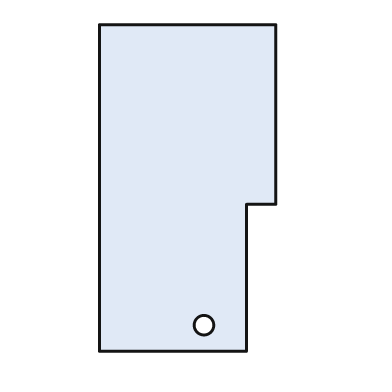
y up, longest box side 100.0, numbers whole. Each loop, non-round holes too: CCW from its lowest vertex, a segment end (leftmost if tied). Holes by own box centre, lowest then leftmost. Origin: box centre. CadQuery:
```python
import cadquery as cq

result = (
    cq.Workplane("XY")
    .moveTo(-27.0, -50.0)
    .lineTo(18.0, -50.0)
    .lineTo(18.0, -5.0)
    .lineTo(27.0, -5.0)
    .lineTo(27.0, 50.0)
    .lineTo(-27.0, 50.0)
    .close()
    .moveTo(5.0, -42.0)
    .circle(3.0)
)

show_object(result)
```